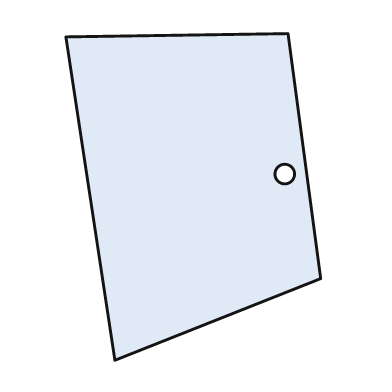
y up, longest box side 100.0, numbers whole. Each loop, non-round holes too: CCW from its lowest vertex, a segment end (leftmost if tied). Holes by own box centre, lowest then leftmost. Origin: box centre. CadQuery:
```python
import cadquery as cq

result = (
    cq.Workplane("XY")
    .moveTo(-24.0, -50.0)
    .lineTo(39.0, -25.0)
    .lineTo(29.0, 50.0)
    .lineTo(-39.0, 49.0)
    .close()
    .moveTo(28.0, 7.0)
    .circle(3.0)
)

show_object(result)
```